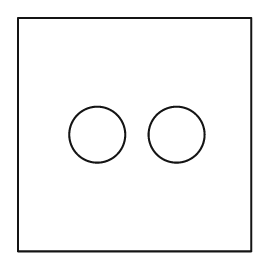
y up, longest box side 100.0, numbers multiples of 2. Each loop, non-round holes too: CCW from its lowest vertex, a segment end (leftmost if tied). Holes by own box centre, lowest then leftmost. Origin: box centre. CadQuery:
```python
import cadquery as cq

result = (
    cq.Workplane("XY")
    .moveTo(-50.0, -50.0)
    .lineTo(50.0, -50.0)
    .lineTo(50.0, 50.0)
    .lineTo(-50.0, 50.0)
    .close()
    .moveTo(-16.0, 0.0)
    .circle(12.0)
    .moveTo(18.0, 0.0)
    .circle(12.0)
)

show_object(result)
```